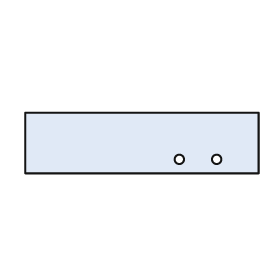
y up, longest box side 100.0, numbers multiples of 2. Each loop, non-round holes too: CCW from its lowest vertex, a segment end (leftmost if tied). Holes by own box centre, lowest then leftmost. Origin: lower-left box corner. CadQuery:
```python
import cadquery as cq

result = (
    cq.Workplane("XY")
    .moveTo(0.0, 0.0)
    .lineTo(100.0, 0.0)
    .lineTo(100.0, 26.0)
    .lineTo(0.0, 26.0)
    .close()
    .moveTo(66.0, 6.0)
    .circle(2.0)
    .moveTo(82.0, 6.0)
    .circle(2.0)
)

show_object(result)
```